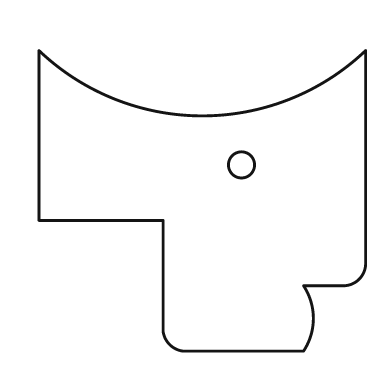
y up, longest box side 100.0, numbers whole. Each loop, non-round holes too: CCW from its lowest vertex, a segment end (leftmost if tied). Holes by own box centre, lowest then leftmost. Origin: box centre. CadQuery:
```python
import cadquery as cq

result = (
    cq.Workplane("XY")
    .moveTo(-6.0, -46.0)
    .lineTo(31.0, -46.0)
    .threePointArc((34.0, -36.0), (31.0, -26.0))
    .lineTo(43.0, -26.0)
    .threePointArc((48.0, -24.0), (50.0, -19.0))
    .lineTo(50.0, 46.0)
    .threePointArc((0.0, 26.0), (-50.0, 46.0))
    .lineTo(-50.0, -6.0)
    .lineTo(-12.0, -6.0)
    .lineTo(-12.0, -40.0)
    .threePointArc((-10.0, -44.0), (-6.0, -46.0))
    .close()
    .moveTo(12.0, 11.0)
    .circle(4.0)
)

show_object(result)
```